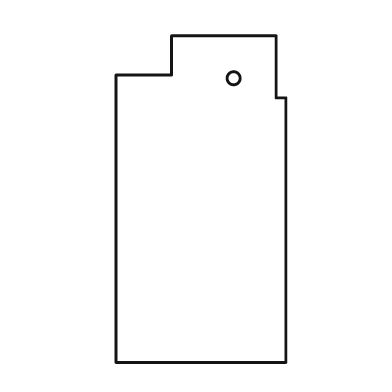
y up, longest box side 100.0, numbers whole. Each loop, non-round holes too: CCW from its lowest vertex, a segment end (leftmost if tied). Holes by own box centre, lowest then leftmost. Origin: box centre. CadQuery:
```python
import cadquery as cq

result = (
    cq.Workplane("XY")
    .moveTo(-26.0, -50.0)
    .lineTo(26.0, -50.0)
    .lineTo(26.0, 31.0)
    .lineTo(23.0, 31.0)
    .lineTo(23.0, 50.0)
    .lineTo(-9.0, 50.0)
    .lineTo(-9.0, 38.0)
    .lineTo(-26.0, 38.0)
    .close()
    .moveTo(10.0, 37.0)
    .circle(2.0)
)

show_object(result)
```